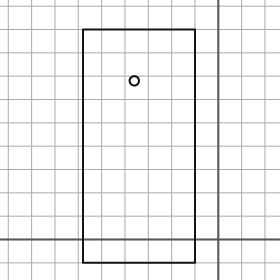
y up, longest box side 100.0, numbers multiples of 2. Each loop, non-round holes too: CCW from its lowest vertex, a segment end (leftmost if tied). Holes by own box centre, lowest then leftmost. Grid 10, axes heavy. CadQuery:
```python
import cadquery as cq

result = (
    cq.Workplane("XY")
    .moveTo(-58.0, -10.0)
    .lineTo(-10.0, -10.0)
    .lineTo(-10.0, 90.0)
    .lineTo(-58.0, 90.0)
    .close()
    .moveTo(-36.0, 68.0)
    .circle(2.0)
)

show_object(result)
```